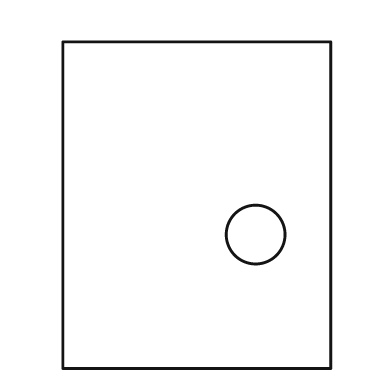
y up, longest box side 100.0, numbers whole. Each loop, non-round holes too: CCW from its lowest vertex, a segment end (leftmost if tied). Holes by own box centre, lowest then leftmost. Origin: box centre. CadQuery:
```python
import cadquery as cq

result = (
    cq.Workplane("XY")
    .moveTo(-41.0, -50.0)
    .lineTo(41.0, -50.0)
    .lineTo(41.0, 50.0)
    .lineTo(-41.0, 50.0)
    .close()
    .moveTo(18.0, -9.0)
    .circle(9.0)
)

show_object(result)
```